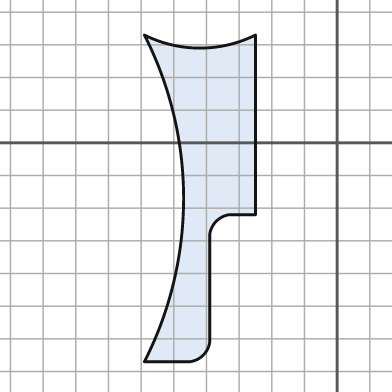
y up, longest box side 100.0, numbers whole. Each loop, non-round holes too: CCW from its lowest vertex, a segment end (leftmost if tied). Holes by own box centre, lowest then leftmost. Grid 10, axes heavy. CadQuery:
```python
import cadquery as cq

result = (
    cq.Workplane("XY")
    .moveTo(-59.0, -67.0)
    .lineTo(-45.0, -67.0)
    .threePointArc((-41.0, -65.0), (-39.0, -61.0))
    .lineTo(-39.0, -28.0)
    .threePointArc((-37.0, -24.0), (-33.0, -22.0))
    .lineTo(-25.0, -22.0)
    .lineTo(-25.0, 33.0)
    .threePointArc((-42.0, 29.0), (-59.0, 33.0))
    .threePointArc((-47.0, -17.0), (-59.0, -67.0))
    .close()
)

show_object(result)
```